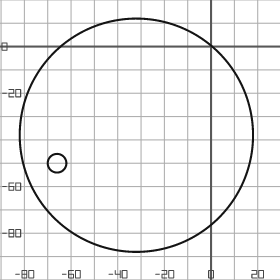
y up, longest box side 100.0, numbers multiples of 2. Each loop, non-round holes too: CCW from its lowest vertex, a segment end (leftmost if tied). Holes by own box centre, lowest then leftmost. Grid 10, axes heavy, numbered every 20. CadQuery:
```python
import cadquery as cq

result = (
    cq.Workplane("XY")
    .moveTo(-32.0, -38.0)
    .circle(50.0)
    .moveTo(-66.0, -50.0)
    .circle(4.0)
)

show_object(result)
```